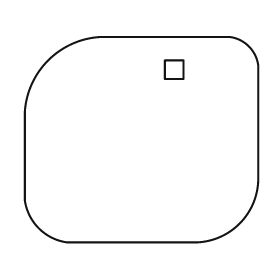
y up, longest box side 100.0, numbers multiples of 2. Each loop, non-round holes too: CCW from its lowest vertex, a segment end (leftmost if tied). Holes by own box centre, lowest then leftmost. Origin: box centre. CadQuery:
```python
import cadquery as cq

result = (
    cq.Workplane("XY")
    .moveTo(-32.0, -44.0)
    .lineTo(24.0, -44.0)
    .threePointArc((42.0, -36.0), (50.0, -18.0))
    .lineTo(50.0, 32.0)
    .threePointArc((46.0, 40.0), (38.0, 44.0))
    .lineTo(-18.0, 44.0)
    .threePointArc((-40.0, 34.0), (-50.0, 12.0))
    .lineTo(-50.0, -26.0)
    .threePointArc((-44.0, -38.0), (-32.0, -44.0))
    .close()
    .moveTo(10.0, 26.0)
    .lineTo(18.0, 26.0)
    .lineTo(18.0, 34.0)
    .lineTo(10.0, 34.0)
    .close()
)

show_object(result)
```